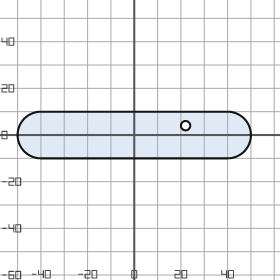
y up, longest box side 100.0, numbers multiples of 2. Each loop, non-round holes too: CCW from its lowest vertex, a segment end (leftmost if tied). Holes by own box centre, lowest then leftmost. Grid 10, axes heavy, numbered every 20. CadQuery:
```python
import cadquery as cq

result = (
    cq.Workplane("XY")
    .moveTo(-40.0, -10.0)
    .lineTo(40.0, -10.0)
    .threePointArc((50.0, 0.0), (40.0, 10.0))
    .lineTo(-40.0, 10.0)
    .threePointArc((-50.0, 0.0), (-40.0, -10.0))
    .close()
    .moveTo(22.0, 4.0)
    .circle(2.0)
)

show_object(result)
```